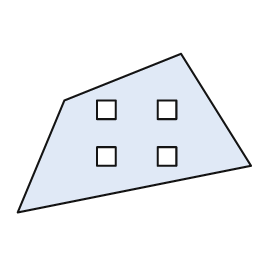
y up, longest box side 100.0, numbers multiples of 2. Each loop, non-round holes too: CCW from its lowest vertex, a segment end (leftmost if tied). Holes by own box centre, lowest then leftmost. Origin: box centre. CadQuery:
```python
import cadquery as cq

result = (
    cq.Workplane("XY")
    .moveTo(-50.0, -34.0)
    .lineTo(50.0, -14.0)
    .lineTo(20.0, 34.0)
    .lineTo(-30.0, 14.0)
    .close()
    .moveTo(-16.0, -14.0)
    .lineTo(-8.0, -14.0)
    .lineTo(-8.0, -6.0)
    .lineTo(-16.0, -6.0)
    .close()
    .moveTo(10.0, -14.0)
    .lineTo(18.0, -14.0)
    .lineTo(18.0, -6.0)
    .lineTo(10.0, -6.0)
    .close()
    .moveTo(-16.0, 6.0)
    .lineTo(-8.0, 6.0)
    .lineTo(-8.0, 14.0)
    .lineTo(-16.0, 14.0)
    .close()
    .moveTo(10.0, 6.0)
    .lineTo(18.0, 6.0)
    .lineTo(18.0, 14.0)
    .lineTo(10.0, 14.0)
    .close()
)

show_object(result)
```